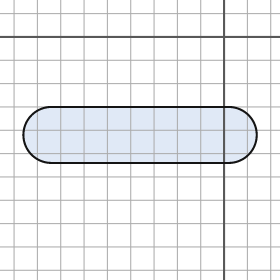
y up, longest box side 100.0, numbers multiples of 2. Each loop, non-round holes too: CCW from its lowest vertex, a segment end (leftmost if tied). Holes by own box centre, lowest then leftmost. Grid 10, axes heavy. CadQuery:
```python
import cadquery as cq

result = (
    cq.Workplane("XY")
    .moveTo(-74.0, -54.0)
    .lineTo(2.0, -54.0)
    .threePointArc((14.0, -42.0), (2.0, -30.0))
    .lineTo(-74.0, -30.0)
    .threePointArc((-86.0, -42.0), (-74.0, -54.0))
    .close()
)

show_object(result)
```